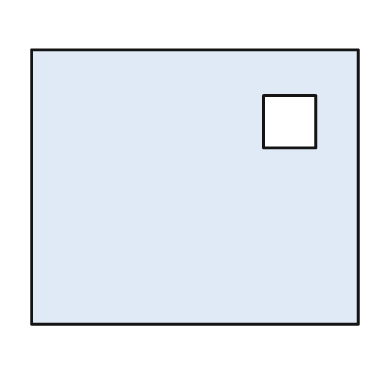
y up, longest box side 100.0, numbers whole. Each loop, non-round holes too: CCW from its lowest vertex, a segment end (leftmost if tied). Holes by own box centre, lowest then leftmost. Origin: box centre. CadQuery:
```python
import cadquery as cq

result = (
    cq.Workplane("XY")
    .moveTo(-50.0, -42.0)
    .lineTo(50.0, -42.0)
    .lineTo(50.0, 42.0)
    .lineTo(-50.0, 42.0)
    .close()
    .moveTo(21.0, 12.0)
    .lineTo(37.0, 12.0)
    .lineTo(37.0, 28.0)
    .lineTo(21.0, 28.0)
    .close()
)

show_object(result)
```